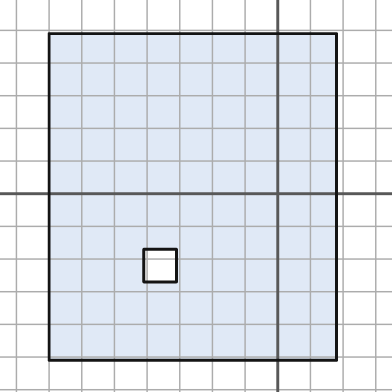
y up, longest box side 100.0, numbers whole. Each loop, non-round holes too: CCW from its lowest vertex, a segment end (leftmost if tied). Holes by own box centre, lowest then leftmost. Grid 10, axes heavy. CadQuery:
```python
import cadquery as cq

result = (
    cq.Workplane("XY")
    .moveTo(-70.0, -51.0)
    .lineTo(18.0, -51.0)
    .lineTo(18.0, 49.0)
    .lineTo(-70.0, 49.0)
    .close()
    .moveTo(-41.0, -27.0)
    .lineTo(-31.0, -27.0)
    .lineTo(-31.0, -17.0)
    .lineTo(-41.0, -17.0)
    .close()
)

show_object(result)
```